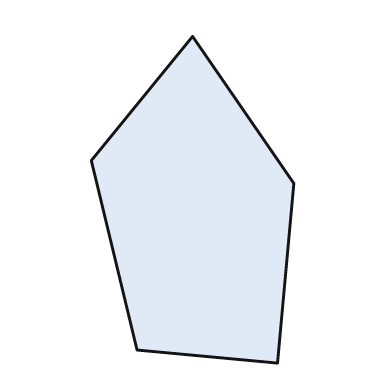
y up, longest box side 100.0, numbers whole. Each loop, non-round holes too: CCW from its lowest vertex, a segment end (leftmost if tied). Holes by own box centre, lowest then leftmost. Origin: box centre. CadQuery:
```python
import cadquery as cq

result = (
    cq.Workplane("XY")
    .moveTo(26.0, -50.0)
    .lineTo(31.0, 5.0)
    .lineTo(0.0, 50.0)
    .lineTo(-31.0, 12.0)
    .lineTo(-17.0, -46.0)
    .close()
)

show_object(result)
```